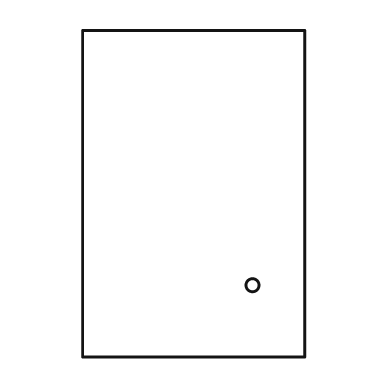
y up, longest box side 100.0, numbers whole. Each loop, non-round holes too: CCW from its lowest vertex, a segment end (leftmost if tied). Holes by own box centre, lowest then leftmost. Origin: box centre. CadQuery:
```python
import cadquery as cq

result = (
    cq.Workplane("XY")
    .moveTo(-34.0, -50.0)
    .lineTo(34.0, -50.0)
    .lineTo(34.0, 50.0)
    .lineTo(-34.0, 50.0)
    .close()
    .moveTo(18.0, -28.0)
    .circle(2.0)
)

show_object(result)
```